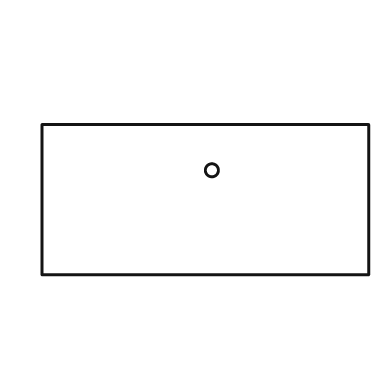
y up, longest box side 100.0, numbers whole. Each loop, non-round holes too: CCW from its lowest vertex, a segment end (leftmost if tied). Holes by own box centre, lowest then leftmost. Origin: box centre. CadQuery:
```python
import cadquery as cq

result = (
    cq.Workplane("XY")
    .moveTo(-50.0, -23.0)
    .lineTo(50.0, -23.0)
    .lineTo(50.0, 23.0)
    .lineTo(-50.0, 23.0)
    .close()
    .moveTo(2.0, 9.0)
    .circle(2.0)
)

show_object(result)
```